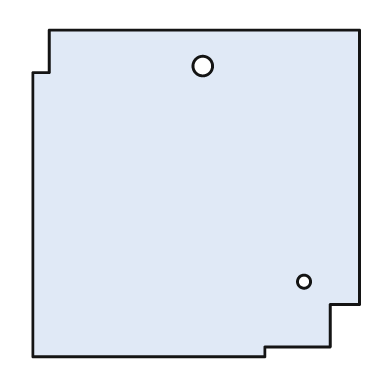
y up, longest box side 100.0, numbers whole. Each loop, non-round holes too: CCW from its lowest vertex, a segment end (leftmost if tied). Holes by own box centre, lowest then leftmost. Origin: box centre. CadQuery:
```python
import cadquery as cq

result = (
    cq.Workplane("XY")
    .moveTo(-50.0, -50.0)
    .lineTo(21.0, -50.0)
    .lineTo(21.0, -47.0)
    .lineTo(41.0, -47.0)
    .lineTo(41.0, -34.0)
    .lineTo(50.0, -34.0)
    .lineTo(50.0, 50.0)
    .lineTo(-45.0, 50.0)
    .lineTo(-45.0, 37.0)
    .lineTo(-50.0, 37.0)
    .close()
    .moveTo(33.0, -27.0)
    .circle(2.0)
    .moveTo(2.0, 39.0)
    .circle(3.0)
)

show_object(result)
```